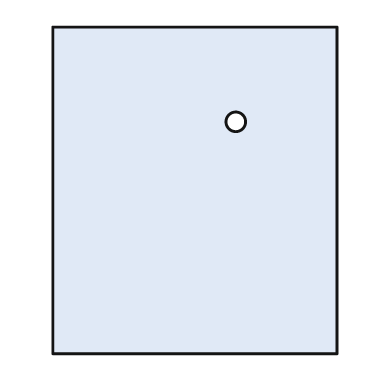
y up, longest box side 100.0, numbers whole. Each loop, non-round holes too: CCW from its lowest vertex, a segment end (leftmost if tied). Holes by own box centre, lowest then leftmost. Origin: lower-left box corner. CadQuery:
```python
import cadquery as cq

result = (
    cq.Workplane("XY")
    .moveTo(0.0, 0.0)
    .lineTo(87.0, 0.0)
    .lineTo(87.0, 100.0)
    .lineTo(0.0, 100.0)
    .close()
    .moveTo(56.0, 71.0)
    .circle(3.0)
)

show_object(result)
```